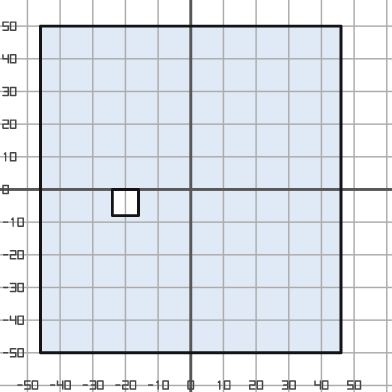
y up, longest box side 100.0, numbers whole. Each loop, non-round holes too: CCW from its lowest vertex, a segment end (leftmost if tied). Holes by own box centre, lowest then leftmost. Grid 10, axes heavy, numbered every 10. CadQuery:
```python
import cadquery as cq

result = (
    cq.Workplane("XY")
    .moveTo(-46.0, -50.0)
    .lineTo(46.0, -50.0)
    .lineTo(46.0, 50.0)
    .lineTo(-46.0, 50.0)
    .close()
    .moveTo(-24.0, -8.0)
    .lineTo(-16.0, -8.0)
    .lineTo(-16.0, 0.0)
    .lineTo(-24.0, 0.0)
    .close()
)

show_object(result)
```